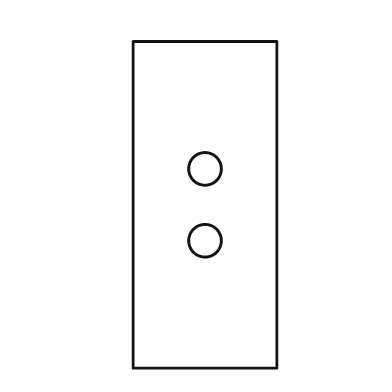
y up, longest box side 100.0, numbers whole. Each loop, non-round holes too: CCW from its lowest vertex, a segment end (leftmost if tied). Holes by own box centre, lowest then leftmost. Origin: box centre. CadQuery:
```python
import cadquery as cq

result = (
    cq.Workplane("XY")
    .moveTo(-22.0, -50.0)
    .lineTo(22.0, -50.0)
    .lineTo(22.0, 50.0)
    .lineTo(-22.0, 50.0)
    .close()
    .moveTo(0.0, -11.0)
    .circle(5.0)
    .moveTo(0.0, 11.0)
    .circle(5.0)
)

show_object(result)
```